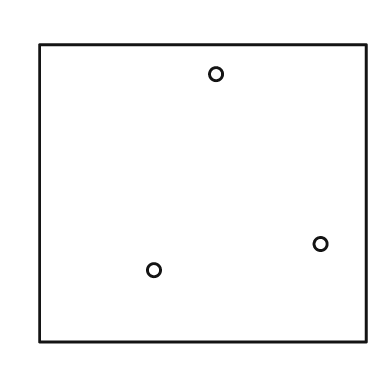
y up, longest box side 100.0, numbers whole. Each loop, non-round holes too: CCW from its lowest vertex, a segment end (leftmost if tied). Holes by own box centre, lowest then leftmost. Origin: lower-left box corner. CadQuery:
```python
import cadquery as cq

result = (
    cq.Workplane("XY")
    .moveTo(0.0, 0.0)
    .lineTo(100.0, 0.0)
    .lineTo(100.0, 91.0)
    .lineTo(0.0, 91.0)
    .close()
    .moveTo(35.0, 22.0)
    .circle(2.0)
    .moveTo(86.0, 30.0)
    .circle(2.0)
    .moveTo(54.0, 82.0)
    .circle(2.0)
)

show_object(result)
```